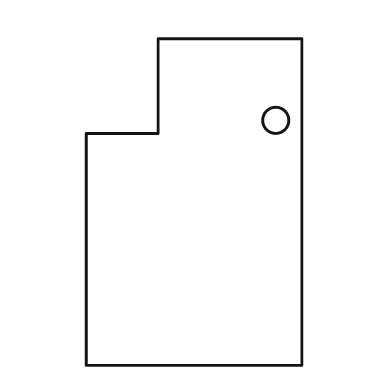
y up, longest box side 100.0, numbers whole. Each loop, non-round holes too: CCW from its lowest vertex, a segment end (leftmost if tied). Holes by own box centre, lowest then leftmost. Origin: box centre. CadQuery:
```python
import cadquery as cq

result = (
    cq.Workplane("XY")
    .moveTo(-33.0, -50.0)
    .lineTo(33.0, -50.0)
    .lineTo(33.0, 50.0)
    .lineTo(-11.0, 50.0)
    .lineTo(-11.0, 21.0)
    .lineTo(-33.0, 21.0)
    .close()
    .moveTo(25.0, 25.0)
    .circle(4.0)
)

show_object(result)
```